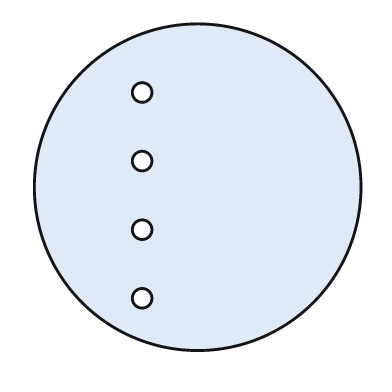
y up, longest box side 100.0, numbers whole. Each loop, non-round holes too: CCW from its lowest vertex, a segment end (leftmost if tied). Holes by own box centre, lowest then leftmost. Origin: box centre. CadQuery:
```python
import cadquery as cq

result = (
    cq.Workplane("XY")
    .moveTo(0.0, 0.0)
    .circle(50.0)
    .moveTo(-17.0, -34.0)
    .circle(3.0)
    .moveTo(-17.0, -13.0)
    .circle(3.0)
    .moveTo(-17.0, 8.0)
    .circle(3.0)
    .moveTo(-17.0, 29.0)
    .circle(3.0)
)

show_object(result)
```